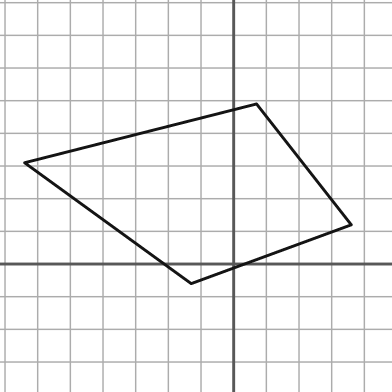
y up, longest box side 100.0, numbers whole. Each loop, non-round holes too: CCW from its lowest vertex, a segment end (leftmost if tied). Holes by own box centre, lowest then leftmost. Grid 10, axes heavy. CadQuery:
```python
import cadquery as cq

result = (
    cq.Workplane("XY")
    .moveTo(-13.0, -6.0)
    .lineTo(36.0, 12.0)
    .lineTo(7.0, 49.0)
    .lineTo(-64.0, 31.0)
    .close()
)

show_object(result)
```